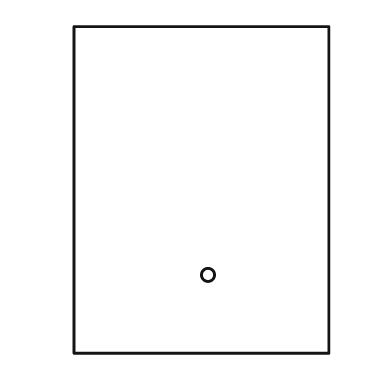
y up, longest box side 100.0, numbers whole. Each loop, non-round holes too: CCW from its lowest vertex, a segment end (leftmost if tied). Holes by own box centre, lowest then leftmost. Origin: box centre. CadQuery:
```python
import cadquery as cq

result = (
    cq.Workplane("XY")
    .moveTo(-39.0, -50.0)
    .lineTo(39.0, -50.0)
    .lineTo(39.0, 50.0)
    .lineTo(-39.0, 50.0)
    .close()
    .moveTo(2.0, -26.0)
    .circle(2.0)
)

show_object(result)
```